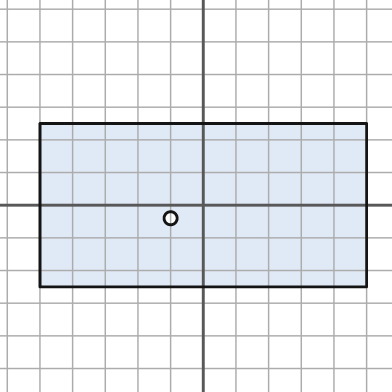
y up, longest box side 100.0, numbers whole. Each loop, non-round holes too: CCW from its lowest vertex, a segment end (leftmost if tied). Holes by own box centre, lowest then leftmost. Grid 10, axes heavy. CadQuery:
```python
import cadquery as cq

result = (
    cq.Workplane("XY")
    .moveTo(-50.0, -25.0)
    .lineTo(50.0, -25.0)
    .lineTo(50.0, 25.0)
    .lineTo(-50.0, 25.0)
    .close()
    .moveTo(-10.0, -4.0)
    .circle(2.0)
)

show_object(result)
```